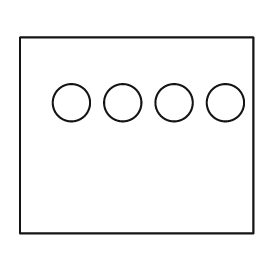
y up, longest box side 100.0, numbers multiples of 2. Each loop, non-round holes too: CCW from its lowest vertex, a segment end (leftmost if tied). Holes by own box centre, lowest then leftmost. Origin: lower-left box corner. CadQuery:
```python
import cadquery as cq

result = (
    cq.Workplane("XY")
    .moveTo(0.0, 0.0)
    .lineTo(100.0, 0.0)
    .lineTo(100.0, 84.0)
    .lineTo(0.0, 84.0)
    .close()
    .moveTo(22.0, 56.0)
    .circle(8.0)
    .moveTo(44.0, 56.0)
    .circle(8.0)
    .moveTo(66.0, 56.0)
    .circle(8.0)
    .moveTo(88.0, 56.0)
    .circle(8.0)
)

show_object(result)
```